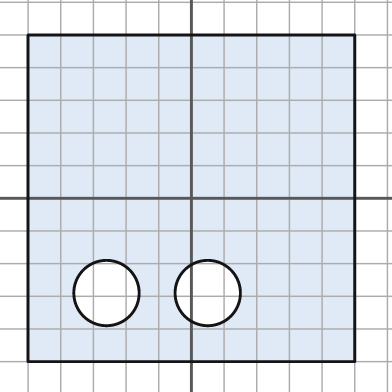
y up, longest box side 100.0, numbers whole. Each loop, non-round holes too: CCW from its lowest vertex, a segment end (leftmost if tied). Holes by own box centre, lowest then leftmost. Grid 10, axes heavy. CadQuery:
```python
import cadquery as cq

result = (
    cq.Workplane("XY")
    .moveTo(-50.0, -50.0)
    .lineTo(50.0, -50.0)
    .lineTo(50.0, 50.0)
    .lineTo(-50.0, 50.0)
    .close()
    .moveTo(-26.0, -29.0)
    .circle(10.0)
    .moveTo(5.0, -29.0)
    .circle(10.0)
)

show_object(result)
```